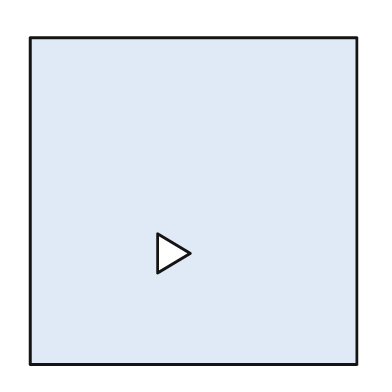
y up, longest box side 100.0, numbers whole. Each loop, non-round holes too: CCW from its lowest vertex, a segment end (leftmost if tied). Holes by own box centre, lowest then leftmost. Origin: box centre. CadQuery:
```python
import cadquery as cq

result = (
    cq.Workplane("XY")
    .moveTo(-50.0, -50.0)
    .lineTo(50.0, -50.0)
    .lineTo(50.0, 50.0)
    .lineTo(-50.0, 50.0)
    .close()
    .moveTo(-11.0, -22.0)
    .lineTo(-1.0, -16.0)
    .lineTo(-11.0, -10.0)
    .close()
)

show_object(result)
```